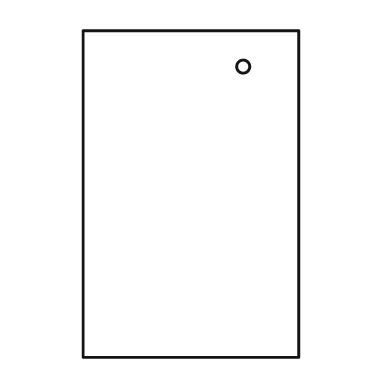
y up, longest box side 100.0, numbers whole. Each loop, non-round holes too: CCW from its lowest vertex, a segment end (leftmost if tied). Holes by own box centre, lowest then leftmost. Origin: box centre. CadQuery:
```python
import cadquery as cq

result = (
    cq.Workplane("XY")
    .moveTo(-33.0, -50.0)
    .lineTo(33.0, -50.0)
    .lineTo(33.0, 50.0)
    .lineTo(-33.0, 50.0)
    .close()
    .moveTo(16.0, 39.0)
    .circle(2.0)
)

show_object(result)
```